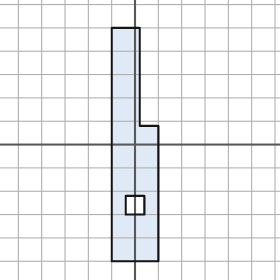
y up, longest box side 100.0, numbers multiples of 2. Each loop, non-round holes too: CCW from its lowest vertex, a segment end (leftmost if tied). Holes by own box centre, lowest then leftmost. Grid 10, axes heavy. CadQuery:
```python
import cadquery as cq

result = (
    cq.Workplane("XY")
    .moveTo(-10.0, -50.0)
    .lineTo(10.0, -50.0)
    .lineTo(10.0, 8.0)
    .lineTo(2.0, 8.0)
    .lineTo(2.0, 50.0)
    .lineTo(-10.0, 50.0)
    .close()
    .moveTo(-4.0, -30.0)
    .lineTo(4.0, -30.0)
    .lineTo(4.0, -22.0)
    .lineTo(-4.0, -22.0)
    .close()
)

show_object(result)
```